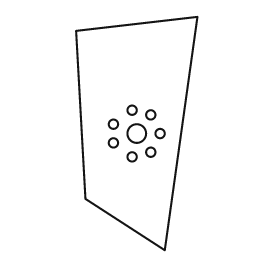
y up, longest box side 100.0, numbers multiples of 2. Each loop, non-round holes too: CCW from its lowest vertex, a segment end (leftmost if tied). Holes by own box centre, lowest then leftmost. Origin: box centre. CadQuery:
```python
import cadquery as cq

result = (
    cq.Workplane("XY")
    .moveTo(12.0, -50.0)
    .lineTo(26.0, 50.0)
    .lineTo(-26.0, 44.0)
    .lineTo(-22.0, -28.0)
    .close()
    .moveTo(-2.0, -10.0)
    .circle(2.0)
    .moveTo(6.0, -8.0)
    .circle(2.0)
    .moveTo(-10.0, -4.0)
    .circle(2.0)
    .moveTo(0.0, 0.0)
    .circle(4.0)
    .moveTo(10.0, 0.0)
    .circle(2.0)
    .moveTo(-10.0, 4.0)
    .circle(2.0)
    .moveTo(6.0, 8.0)
    .circle(2.0)
    .moveTo(-2.0, 10.0)
    .circle(2.0)
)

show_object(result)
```